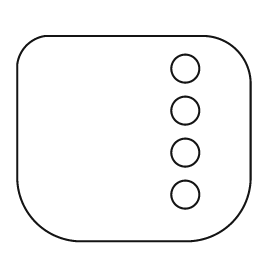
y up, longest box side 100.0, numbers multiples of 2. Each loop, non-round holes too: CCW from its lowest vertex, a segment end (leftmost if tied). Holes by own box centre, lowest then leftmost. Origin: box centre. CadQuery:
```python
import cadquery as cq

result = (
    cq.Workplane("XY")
    .moveTo(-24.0, -44.0)
    .lineTo(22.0, -44.0)
    .threePointArc((42.0, -36.0), (50.0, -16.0))
    .lineTo(50.0, 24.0)
    .threePointArc((44.0, 38.0), (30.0, 44.0))
    .lineTo(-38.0, 44.0)
    .threePointArc((-46.0, 40.0), (-50.0, 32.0))
    .lineTo(-50.0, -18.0)
    .threePointArc((-42.0, -36.0), (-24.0, -44.0))
    .close()
    .moveTo(22.0, -24.0)
    .circle(6.0)
    .moveTo(22.0, -6.0)
    .circle(6.0)
    .moveTo(22.0, 12.0)
    .circle(6.0)
    .moveTo(22.0, 30.0)
    .circle(6.0)
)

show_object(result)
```